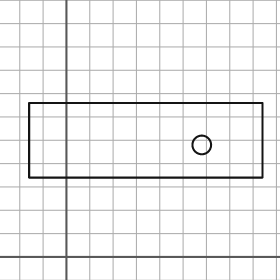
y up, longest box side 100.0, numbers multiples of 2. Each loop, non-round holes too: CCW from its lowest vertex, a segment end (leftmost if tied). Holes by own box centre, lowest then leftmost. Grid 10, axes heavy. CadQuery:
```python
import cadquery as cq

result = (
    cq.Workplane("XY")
    .moveTo(-16.0, 34.0)
    .lineTo(84.0, 34.0)
    .lineTo(84.0, 66.0)
    .lineTo(-16.0, 66.0)
    .close()
    .moveTo(58.0, 48.0)
    .circle(4.0)
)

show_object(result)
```